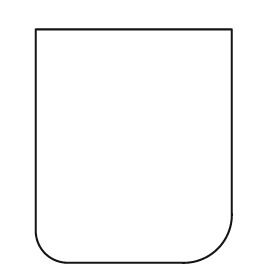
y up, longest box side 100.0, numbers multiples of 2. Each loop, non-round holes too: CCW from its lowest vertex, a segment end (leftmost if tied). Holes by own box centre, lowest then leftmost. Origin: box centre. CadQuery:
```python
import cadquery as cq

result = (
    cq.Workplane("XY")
    .moveTo(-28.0, -50.0)
    .lineTo(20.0, -50.0)
    .threePointArc((36.0, -44.0), (42.0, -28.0))
    .lineTo(42.0, 50.0)
    .lineTo(-42.0, 50.0)
    .lineTo(-42.0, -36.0)
    .threePointArc((-38.0, -46.0), (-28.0, -50.0))
    .close()
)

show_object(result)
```